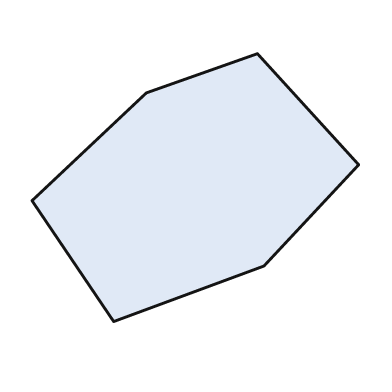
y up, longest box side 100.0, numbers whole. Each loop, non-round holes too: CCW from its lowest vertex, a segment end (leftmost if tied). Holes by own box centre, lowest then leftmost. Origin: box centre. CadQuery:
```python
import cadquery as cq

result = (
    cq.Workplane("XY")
    .moveTo(-25.0, -41.0)
    .lineTo(21.0, -24.0)
    .lineTo(50.0, 7.0)
    .lineTo(19.0, 41.0)
    .lineTo(-15.0, 29.0)
    .lineTo(-50.0, -4.0)
    .close()
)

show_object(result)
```